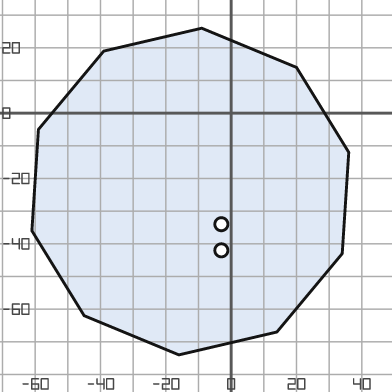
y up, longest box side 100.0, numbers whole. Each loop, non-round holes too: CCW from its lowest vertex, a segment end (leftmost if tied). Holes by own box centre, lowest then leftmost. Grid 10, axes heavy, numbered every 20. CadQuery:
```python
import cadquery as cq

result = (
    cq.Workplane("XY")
    .moveTo(-16.0, -74.0)
    .lineTo(14.0, -67.0)
    .lineTo(34.0, -43.0)
    .lineTo(36.0, -12.0)
    .lineTo(20.0, 14.0)
    .lineTo(-9.0, 26.0)
    .lineTo(-39.0, 19.0)
    .lineTo(-59.0, -5.0)
    .lineTo(-61.0, -36.0)
    .lineTo(-45.0, -62.0)
    .close()
    .moveTo(-3.0, -42.0)
    .circle(2.0)
    .moveTo(-3.0, -34.0)
    .circle(2.0)
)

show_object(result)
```